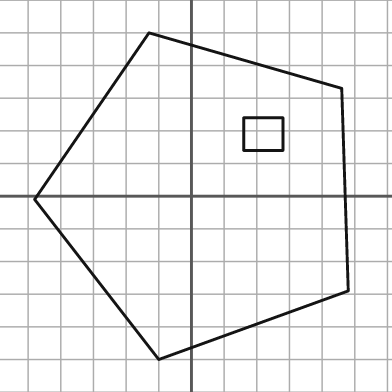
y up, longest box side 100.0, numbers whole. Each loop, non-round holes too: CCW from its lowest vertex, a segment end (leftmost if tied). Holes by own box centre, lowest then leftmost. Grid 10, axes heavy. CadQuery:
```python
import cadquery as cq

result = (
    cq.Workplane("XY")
    .moveTo(-10.0, -50.0)
    .lineTo(48.0, -29.0)
    .lineTo(46.0, 33.0)
    .lineTo(-13.0, 50.0)
    .lineTo(-48.0, -1.0)
    .close()
    .moveTo(16.0, 14.0)
    .lineTo(28.0, 14.0)
    .lineTo(28.0, 24.0)
    .lineTo(16.0, 24.0)
    .close()
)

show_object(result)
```